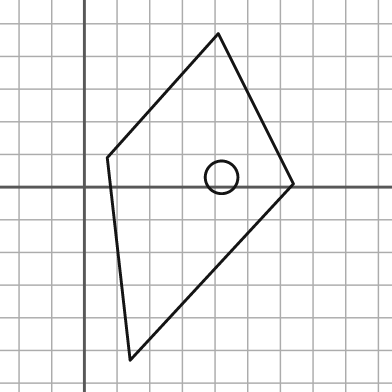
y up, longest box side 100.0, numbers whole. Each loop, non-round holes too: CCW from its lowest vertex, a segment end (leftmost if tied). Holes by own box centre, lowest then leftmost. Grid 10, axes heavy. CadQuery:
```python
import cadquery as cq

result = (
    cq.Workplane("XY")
    .moveTo(14.0, -53.0)
    .lineTo(64.0, 1.0)
    .lineTo(41.0, 47.0)
    .lineTo(7.0, 9.0)
    .close()
    .moveTo(42.0, 3.0)
    .circle(5.0)
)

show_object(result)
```